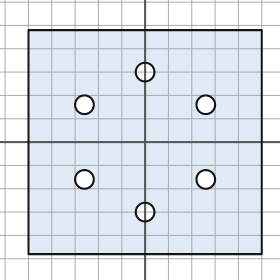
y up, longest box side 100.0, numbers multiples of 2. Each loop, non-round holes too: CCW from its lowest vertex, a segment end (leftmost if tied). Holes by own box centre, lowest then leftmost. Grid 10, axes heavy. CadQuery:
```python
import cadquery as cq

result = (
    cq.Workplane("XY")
    .moveTo(-50.0, -48.0)
    .lineTo(50.0, -48.0)
    .lineTo(50.0, 48.0)
    .lineTo(-50.0, 48.0)
    .close()
    .moveTo(0.0, -30.0)
    .circle(4.0)
    .moveTo(-26.0, -16.0)
    .circle(4.0)
    .moveTo(26.0, -16.0)
    .circle(4.0)
    .moveTo(-26.0, 16.0)
    .circle(4.0)
    .moveTo(26.0, 16.0)
    .circle(4.0)
    .moveTo(0.0, 30.0)
    .circle(4.0)
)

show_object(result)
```